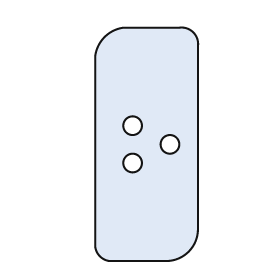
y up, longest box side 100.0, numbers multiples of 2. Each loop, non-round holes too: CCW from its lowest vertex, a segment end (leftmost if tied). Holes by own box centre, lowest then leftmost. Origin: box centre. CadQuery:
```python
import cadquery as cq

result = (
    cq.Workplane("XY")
    .moveTo(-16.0, -50.0)
    .lineTo(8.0, -50.0)
    .threePointArc((18.0, -46.0), (22.0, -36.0))
    .lineTo(22.0, 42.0)
    .threePointArc((20.0, 48.0), (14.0, 50.0))
    .lineTo(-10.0, 50.0)
    .threePointArc((-18.0, 46.0), (-22.0, 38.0))
    .lineTo(-22.0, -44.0)
    .threePointArc((-20.0, -48.0), (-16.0, -50.0))
    .close()
    .moveTo(-6.0, -8.0)
    .circle(4.0)
    .moveTo(10.0, 0.0)
    .circle(4.0)
    .moveTo(-6.0, 8.0)
    .circle(4.0)
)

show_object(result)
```